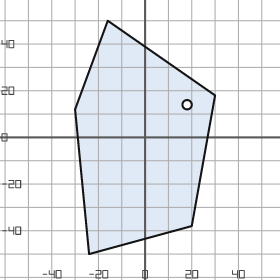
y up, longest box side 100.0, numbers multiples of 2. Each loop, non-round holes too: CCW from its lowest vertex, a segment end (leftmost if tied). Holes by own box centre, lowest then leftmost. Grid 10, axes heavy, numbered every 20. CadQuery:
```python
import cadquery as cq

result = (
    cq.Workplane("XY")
    .moveTo(-24.0, -50.0)
    .lineTo(20.0, -38.0)
    .lineTo(30.0, 18.0)
    .lineTo(-16.0, 50.0)
    .lineTo(-30.0, 12.0)
    .close()
    .moveTo(18.0, 14.0)
    .circle(2.0)
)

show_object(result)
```